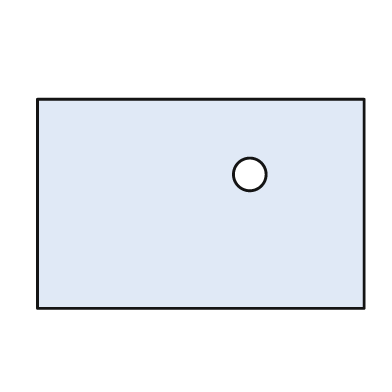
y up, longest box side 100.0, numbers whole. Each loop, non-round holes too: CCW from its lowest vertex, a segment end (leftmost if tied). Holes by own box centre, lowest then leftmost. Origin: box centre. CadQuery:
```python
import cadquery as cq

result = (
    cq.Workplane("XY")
    .moveTo(-50.0, -32.0)
    .lineTo(50.0, -32.0)
    .lineTo(50.0, 32.0)
    .lineTo(-50.0, 32.0)
    .close()
    .moveTo(15.0, 9.0)
    .circle(5.0)
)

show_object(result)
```